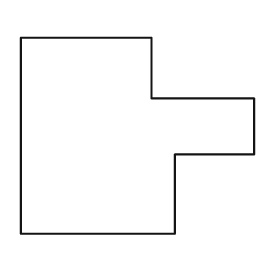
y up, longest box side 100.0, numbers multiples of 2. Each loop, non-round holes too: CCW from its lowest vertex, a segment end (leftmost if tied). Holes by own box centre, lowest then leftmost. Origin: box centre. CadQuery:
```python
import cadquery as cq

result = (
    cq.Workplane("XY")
    .moveTo(-50.0, -42.0)
    .lineTo(16.0, -42.0)
    .lineTo(16.0, -8.0)
    .lineTo(50.0, -8.0)
    .lineTo(50.0, 16.0)
    .lineTo(6.0, 16.0)
    .lineTo(6.0, 42.0)
    .lineTo(-50.0, 42.0)
    .close()
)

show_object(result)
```